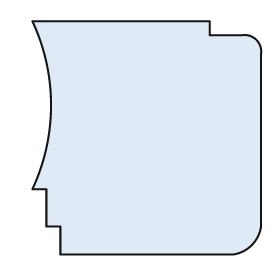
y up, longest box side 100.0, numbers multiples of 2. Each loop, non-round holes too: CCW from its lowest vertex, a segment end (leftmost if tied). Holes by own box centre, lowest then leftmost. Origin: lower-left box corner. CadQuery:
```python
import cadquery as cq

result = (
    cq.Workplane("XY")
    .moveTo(12.0, 0.0)
    .lineTo(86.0, 0.0)
    .threePointArc((94.0, 4.0), (98.0, 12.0))
    .lineTo(98.0, 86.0)
    .threePointArc((96.0, 92.0), (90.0, 94.0))
    .lineTo(76.0, 94.0)
    .lineTo(76.0, 100.0)
    .lineTo(0.0, 100.0)
    .threePointArc((8.0, 64.0), (0.0, 28.0))
    .lineTo(6.0, 28.0)
    .lineTo(6.0, 12.0)
    .lineTo(12.0, 12.0)
    .close()
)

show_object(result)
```